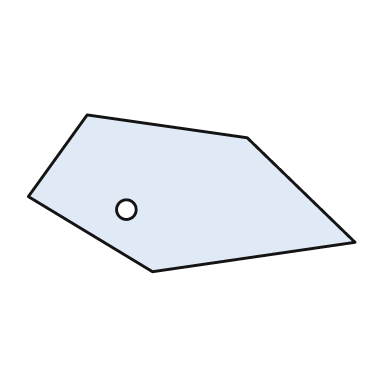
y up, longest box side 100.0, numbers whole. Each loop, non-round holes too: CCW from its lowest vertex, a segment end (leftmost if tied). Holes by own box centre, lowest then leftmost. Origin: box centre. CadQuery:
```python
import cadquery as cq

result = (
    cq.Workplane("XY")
    .moveTo(-12.0, -24.0)
    .lineTo(50.0, -15.0)
    .lineTo(17.0, 17.0)
    .lineTo(-32.0, 24.0)
    .lineTo(-50.0, -1.0)
    .close()
    .moveTo(-20.0, -5.0)
    .circle(3.0)
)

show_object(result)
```